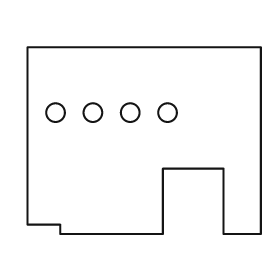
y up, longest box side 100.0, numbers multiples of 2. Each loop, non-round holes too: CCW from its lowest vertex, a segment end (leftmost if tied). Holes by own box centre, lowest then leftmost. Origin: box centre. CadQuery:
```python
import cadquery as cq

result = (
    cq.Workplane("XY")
    .moveTo(-36.0, -40.0)
    .lineTo(8.0, -40.0)
    .lineTo(8.0, -12.0)
    .lineTo(34.0, -12.0)
    .lineTo(34.0, -40.0)
    .lineTo(50.0, -40.0)
    .lineTo(50.0, 40.0)
    .lineTo(-50.0, 40.0)
    .lineTo(-50.0, -36.0)
    .lineTo(-36.0, -36.0)
    .close()
    .moveTo(-38.0, 12.0)
    .circle(4.0)
    .moveTo(-22.0, 12.0)
    .circle(4.0)
    .moveTo(-6.0, 12.0)
    .circle(4.0)
    .moveTo(10.0, 12.0)
    .circle(4.0)
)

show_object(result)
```